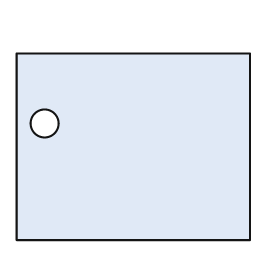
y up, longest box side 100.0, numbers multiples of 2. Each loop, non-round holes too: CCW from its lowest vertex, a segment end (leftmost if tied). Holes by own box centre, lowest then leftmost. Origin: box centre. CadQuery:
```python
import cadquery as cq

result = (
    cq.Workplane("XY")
    .moveTo(-50.0, -40.0)
    .lineTo(50.0, -40.0)
    .lineTo(50.0, 40.0)
    .lineTo(-50.0, 40.0)
    .close()
    .moveTo(-38.0, 10.0)
    .circle(6.0)
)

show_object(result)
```